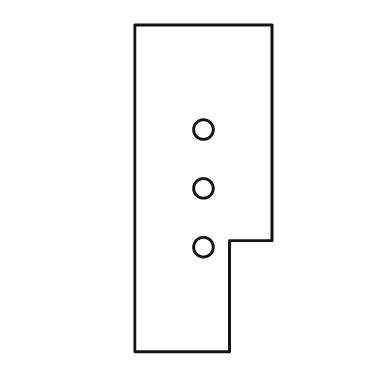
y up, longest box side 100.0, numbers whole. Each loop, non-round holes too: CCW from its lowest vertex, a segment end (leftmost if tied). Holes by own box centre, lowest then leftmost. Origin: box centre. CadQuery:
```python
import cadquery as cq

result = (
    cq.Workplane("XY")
    .moveTo(-21.0, -50.0)
    .lineTo(8.0, -50.0)
    .lineTo(8.0, -16.0)
    .lineTo(21.0, -16.0)
    .lineTo(21.0, 50.0)
    .lineTo(-21.0, 50.0)
    .close()
    .moveTo(0.0, -18.0)
    .circle(3.0)
    .moveTo(0.0, 0.0)
    .circle(3.0)
    .moveTo(0.0, 18.0)
    .circle(3.0)
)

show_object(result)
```